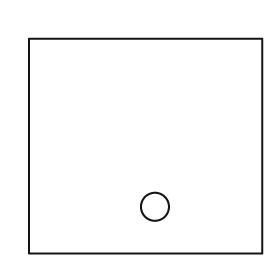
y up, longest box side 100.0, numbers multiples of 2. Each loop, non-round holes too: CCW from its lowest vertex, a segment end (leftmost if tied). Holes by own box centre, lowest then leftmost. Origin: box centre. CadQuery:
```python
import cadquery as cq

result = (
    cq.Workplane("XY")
    .moveTo(-50.0, -46.0)
    .lineTo(50.0, -46.0)
    .lineTo(50.0, 46.0)
    .lineTo(-50.0, 46.0)
    .close()
    .moveTo(4.0, -26.0)
    .circle(6.0)
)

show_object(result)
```